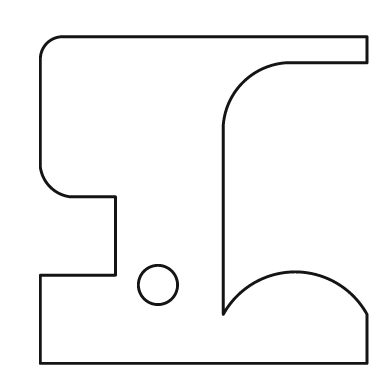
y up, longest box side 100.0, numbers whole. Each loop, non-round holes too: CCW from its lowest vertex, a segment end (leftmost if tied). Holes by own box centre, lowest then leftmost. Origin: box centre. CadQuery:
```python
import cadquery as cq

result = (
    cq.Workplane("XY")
    .moveTo(-50.0, -50.0)
    .lineTo(50.0, -50.0)
    .lineTo(50.0, -35.0)
    .threePointArc((28.0, -22.0), (6.0, -35.0))
    .lineTo(6.0, 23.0)
    .threePointArc((12.0, 36.0), (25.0, 42.0))
    .lineTo(50.0, 42.0)
    .lineTo(50.0, 50.0)
    .lineTo(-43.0, 50.0)
    .threePointArc((-48.0, 48.0), (-50.0, 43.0))
    .lineTo(-50.0, 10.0)
    .threePointArc((-47.0, 4.0), (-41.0, 1.0))
    .lineTo(-27.0, 1.0)
    .lineTo(-27.0, -23.0)
    .lineTo(-50.0, -23.0)
    .close()
    .moveTo(-14.0, -26.0)
    .circle(6.0)
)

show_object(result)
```